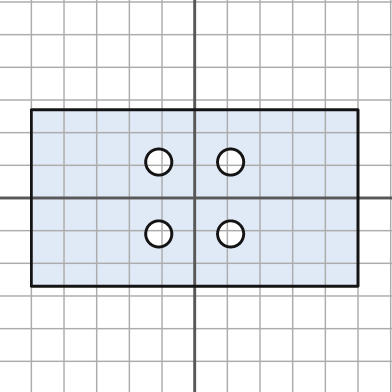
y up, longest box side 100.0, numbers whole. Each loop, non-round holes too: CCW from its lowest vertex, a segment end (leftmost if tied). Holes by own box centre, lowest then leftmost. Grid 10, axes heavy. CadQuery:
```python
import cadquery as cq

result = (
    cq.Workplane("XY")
    .moveTo(-50.0, -27.0)
    .lineTo(50.0, -27.0)
    .lineTo(50.0, 27.0)
    .lineTo(-50.0, 27.0)
    .close()
    .moveTo(-11.0, -11.0)
    .circle(4.0)
    .moveTo(11.0, -11.0)
    .circle(4.0)
    .moveTo(-11.0, 11.0)
    .circle(4.0)
    .moveTo(11.0, 11.0)
    .circle(4.0)
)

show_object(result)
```